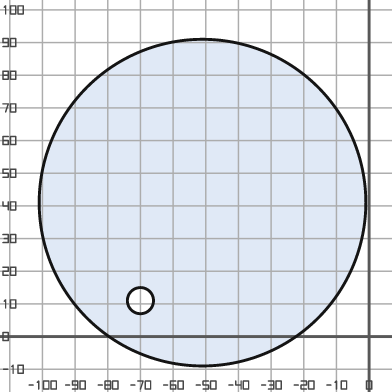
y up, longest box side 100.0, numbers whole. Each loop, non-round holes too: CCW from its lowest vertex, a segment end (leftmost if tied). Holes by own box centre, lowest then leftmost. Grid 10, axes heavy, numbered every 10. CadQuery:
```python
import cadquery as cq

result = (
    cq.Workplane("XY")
    .moveTo(-51.0, 41.0)
    .circle(50.0)
    .moveTo(-70.0, 11.0)
    .circle(4.0)
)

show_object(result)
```